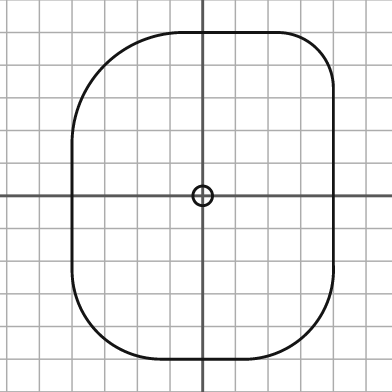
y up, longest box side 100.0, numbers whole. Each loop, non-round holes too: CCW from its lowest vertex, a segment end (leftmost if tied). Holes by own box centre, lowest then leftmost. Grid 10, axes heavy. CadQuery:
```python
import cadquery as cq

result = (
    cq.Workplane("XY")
    .moveTo(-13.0, -50.0)
    .lineTo(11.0, -50.0)
    .threePointArc((32.0, -42.0), (40.0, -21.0))
    .lineTo(40.0, 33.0)
    .threePointArc((35.0, 45.0), (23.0, 50.0))
    .lineTo(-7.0, 50.0)
    .threePointArc((-30.0, 40.0), (-40.0, 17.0))
    .lineTo(-40.0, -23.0)
    .threePointArc((-32.0, -42.0), (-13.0, -50.0))
    .close()
    .moveTo(0.0, 0.0)
    .circle(3.0)
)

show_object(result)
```